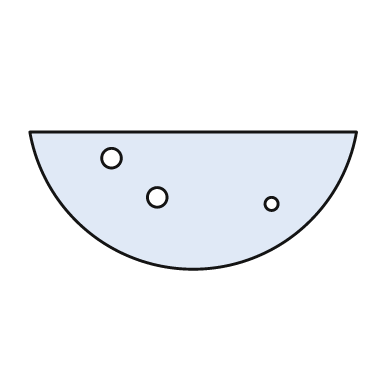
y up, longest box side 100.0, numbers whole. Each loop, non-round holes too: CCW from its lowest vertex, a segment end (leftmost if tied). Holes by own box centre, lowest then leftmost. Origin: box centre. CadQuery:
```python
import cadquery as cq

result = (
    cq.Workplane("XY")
    .moveTo(-50.0, 21.0)
    .threePointArc((0.0, -21.0), (50.0, 21.0))
    .close()
    .moveTo(24.0, -1.0)
    .circle(2.0)
    .moveTo(-11.0, 1.0)
    .circle(3.0)
    .moveTo(-25.0, 13.0)
    .circle(3.0)
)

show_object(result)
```